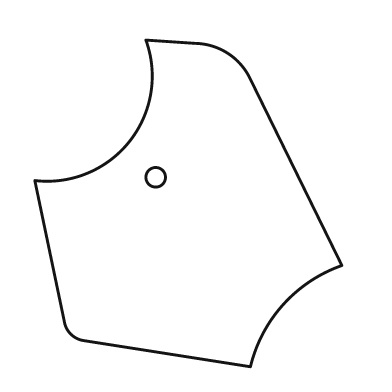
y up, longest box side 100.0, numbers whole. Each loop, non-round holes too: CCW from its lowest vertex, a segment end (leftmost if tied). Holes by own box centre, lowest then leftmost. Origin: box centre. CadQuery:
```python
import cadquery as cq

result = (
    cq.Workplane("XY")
    .moveTo(19.0, -50.0)
    .threePointArc((29.0, -31.0), (47.0, -19.0))
    .lineTo(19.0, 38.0)
    .threePointArc((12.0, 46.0), (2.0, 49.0))
    .lineTo(-13.0, 50.0)
    .threePointArc((-18.0, 19.0), (-47.0, 7.0))
    .lineTo(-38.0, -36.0)
    .threePointArc((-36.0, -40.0), (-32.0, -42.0))
    .close()
    .moveTo(-10.0, 8.0)
    .circle(3.0)
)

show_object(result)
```